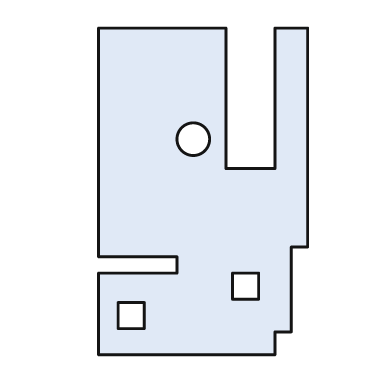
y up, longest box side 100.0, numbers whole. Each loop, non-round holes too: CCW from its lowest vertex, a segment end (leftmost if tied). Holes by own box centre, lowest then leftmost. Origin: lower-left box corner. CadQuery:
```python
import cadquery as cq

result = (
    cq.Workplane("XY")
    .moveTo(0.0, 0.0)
    .lineTo(54.0, 0.0)
    .lineTo(54.0, 7.0)
    .lineTo(59.0, 7.0)
    .lineTo(59.0, 33.0)
    .lineTo(64.0, 33.0)
    .lineTo(64.0, 100.0)
    .lineTo(54.0, 100.0)
    .lineTo(54.0, 57.0)
    .lineTo(39.0, 57.0)
    .lineTo(39.0, 100.0)
    .lineTo(0.0, 100.0)
    .lineTo(0.0, 30.0)
    .lineTo(24.0, 30.0)
    .lineTo(24.0, 25.0)
    .lineTo(0.0, 25.0)
    .close()
    .moveTo(6.0, 8.0)
    .lineTo(14.0, 8.0)
    .lineTo(14.0, 16.0)
    .lineTo(6.0, 16.0)
    .close()
    .moveTo(41.0, 17.0)
    .lineTo(49.0, 17.0)
    .lineTo(49.0, 25.0)
    .lineTo(41.0, 25.0)
    .close()
    .moveTo(29.0, 66.0)
    .circle(5.0)
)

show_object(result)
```